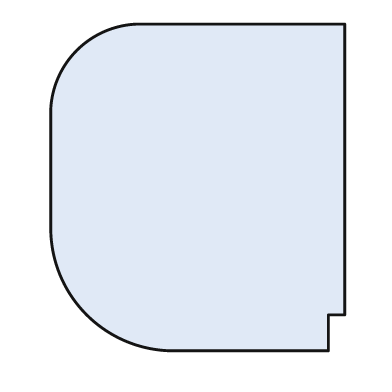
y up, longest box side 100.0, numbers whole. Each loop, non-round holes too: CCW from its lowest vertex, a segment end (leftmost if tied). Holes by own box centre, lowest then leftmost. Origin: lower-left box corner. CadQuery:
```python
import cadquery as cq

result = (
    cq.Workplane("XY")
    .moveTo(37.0, 0.0)
    .lineTo(85.0, 0.0)
    .lineTo(85.0, 11.0)
    .lineTo(90.0, 11.0)
    .lineTo(90.0, 100.0)
    .lineTo(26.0, 100.0)
    .threePointArc((8.0, 92.0), (0.0, 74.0))
    .lineTo(0.0, 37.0)
    .threePointArc((11.0, 11.0), (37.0, 0.0))
    .close()
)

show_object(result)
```